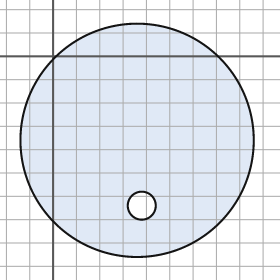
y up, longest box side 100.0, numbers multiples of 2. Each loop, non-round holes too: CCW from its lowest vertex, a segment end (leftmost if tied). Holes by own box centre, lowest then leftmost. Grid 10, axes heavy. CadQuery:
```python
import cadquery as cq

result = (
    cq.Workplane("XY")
    .moveTo(36.0, -36.0)
    .circle(50.0)
    .moveTo(38.0, -64.0)
    .circle(6.0)
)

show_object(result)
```